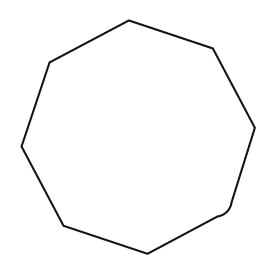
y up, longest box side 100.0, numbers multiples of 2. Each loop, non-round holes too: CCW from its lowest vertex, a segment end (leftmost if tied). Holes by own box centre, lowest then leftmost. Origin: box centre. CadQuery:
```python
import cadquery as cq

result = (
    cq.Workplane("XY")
    .moveTo(4.0, -50.0)
    .lineTo(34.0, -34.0)
    .threePointArc((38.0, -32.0), (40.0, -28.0))
    .lineTo(50.0, 4.0)
    .lineTo(32.0, 38.0)
    .lineTo(-4.0, 50.0)
    .lineTo(-38.0, 32.0)
    .lineTo(-50.0, -4.0)
    .lineTo(-32.0, -38.0)
    .close()
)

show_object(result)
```